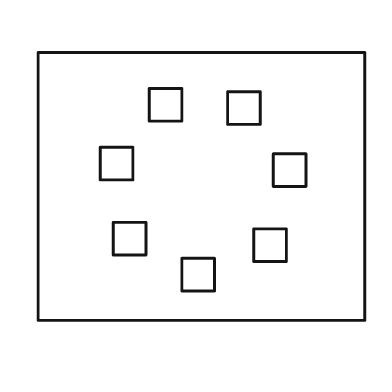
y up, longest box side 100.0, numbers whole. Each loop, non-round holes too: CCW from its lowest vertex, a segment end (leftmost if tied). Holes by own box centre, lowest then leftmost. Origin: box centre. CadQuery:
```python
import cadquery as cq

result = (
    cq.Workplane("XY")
    .moveTo(-50.0, -41.0)
    .lineTo(50.0, -41.0)
    .lineTo(50.0, 41.0)
    .lineTo(-50.0, 41.0)
    .close()
    .moveTo(-6.0, -32.0)
    .lineTo(4.0, -32.0)
    .lineTo(4.0, -22.0)
    .lineTo(-6.0, -22.0)
    .close()
    .moveTo(16.0, -23.0)
    .lineTo(26.0, -23.0)
    .lineTo(26.0, -13.0)
    .lineTo(16.0, -13.0)
    .close()
    .moveTo(-27.0, -21.0)
    .lineTo(-17.0, -21.0)
    .lineTo(-17.0, -11.0)
    .lineTo(-27.0, -11.0)
    .close()
    .moveTo(22.0, 0.0)
    .lineTo(32.0, 0.0)
    .lineTo(32.0, 10.0)
    .lineTo(22.0, 10.0)
    .close()
    .moveTo(-31.0, 2.0)
    .lineTo(-21.0, 2.0)
    .lineTo(-21.0, 12.0)
    .lineTo(-31.0, 12.0)
    .close()
    .moveTo(8.0, 19.0)
    .lineTo(18.0, 19.0)
    .lineTo(18.0, 29.0)
    .lineTo(8.0, 29.0)
    .close()
    .moveTo(-16.0, 20.0)
    .lineTo(-6.0, 20.0)
    .lineTo(-6.0, 30.0)
    .lineTo(-16.0, 30.0)
    .close()
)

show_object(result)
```